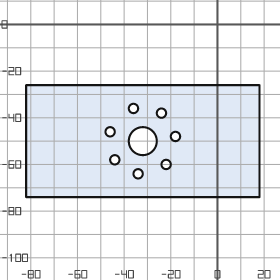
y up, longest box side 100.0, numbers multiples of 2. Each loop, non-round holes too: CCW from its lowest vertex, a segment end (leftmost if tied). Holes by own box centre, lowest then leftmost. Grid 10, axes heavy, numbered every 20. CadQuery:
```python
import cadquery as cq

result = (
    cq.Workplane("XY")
    .moveTo(-82.0, -74.0)
    .lineTo(18.0, -74.0)
    .lineTo(18.0, -26.0)
    .lineTo(-82.0, -26.0)
    .close()
    .moveTo(-34.0, -64.0)
    .circle(2.0)
    .moveTo(-22.0, -60.0)
    .circle(2.0)
    .moveTo(-44.0, -58.0)
    .circle(2.0)
    .moveTo(-32.0, -50.0)
    .circle(6.0)
    .moveTo(-18.0, -48.0)
    .circle(2.0)
    .moveTo(-46.0, -46.0)
    .circle(2.0)
    .moveTo(-24.0, -38.0)
    .circle(2.0)
    .moveTo(-36.0, -36.0)
    .circle(2.0)
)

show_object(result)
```